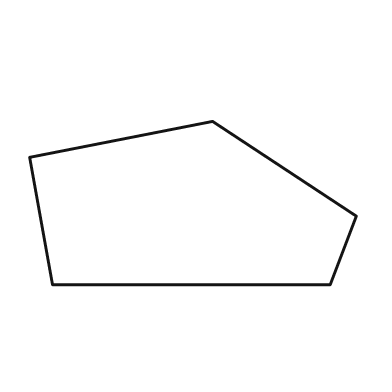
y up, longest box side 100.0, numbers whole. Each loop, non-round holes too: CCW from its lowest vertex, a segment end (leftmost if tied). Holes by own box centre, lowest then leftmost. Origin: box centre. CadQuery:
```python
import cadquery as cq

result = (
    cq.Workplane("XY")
    .moveTo(-43.0, -25.0)
    .lineTo(42.0, -25.0)
    .lineTo(50.0, -4.0)
    .lineTo(6.0, 25.0)
    .lineTo(-50.0, 14.0)
    .close()
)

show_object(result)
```